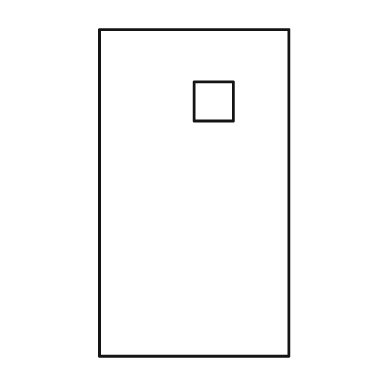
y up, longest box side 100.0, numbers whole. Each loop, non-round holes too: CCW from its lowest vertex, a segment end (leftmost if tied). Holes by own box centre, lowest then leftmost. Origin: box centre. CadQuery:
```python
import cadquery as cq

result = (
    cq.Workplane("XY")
    .moveTo(-29.0, -50.0)
    .lineTo(29.0, -50.0)
    .lineTo(29.0, 50.0)
    .lineTo(-29.0, 50.0)
    .close()
    .moveTo(0.0, 22.0)
    .lineTo(12.0, 22.0)
    .lineTo(12.0, 34.0)
    .lineTo(0.0, 34.0)
    .close()
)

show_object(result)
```